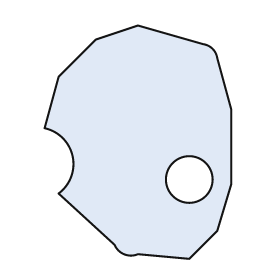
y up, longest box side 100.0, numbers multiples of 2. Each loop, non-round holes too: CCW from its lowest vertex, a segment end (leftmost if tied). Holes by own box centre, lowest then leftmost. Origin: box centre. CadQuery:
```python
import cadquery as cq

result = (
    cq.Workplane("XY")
    .moveTo(22.0, -50.0)
    .lineTo(34.0, -38.0)
    .lineTo(40.0, -18.0)
    .lineTo(40.0, 14.0)
    .lineTo(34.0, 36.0)
    .threePointArc((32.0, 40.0), (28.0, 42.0))
    .lineTo(0.0, 50.0)
    .lineTo(-18.0, 44.0)
    .lineTo(-34.0, 28.0)
    .lineTo(-40.0, 6.0)
    .threePointArc((-28.0, -6.0), (-34.0, -22.0))
    .lineTo(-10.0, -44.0)
    .threePointArc((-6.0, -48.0), (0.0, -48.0))
    .close()
    .moveTo(22.0, -16.0)
    .circle(10.0)
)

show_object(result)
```